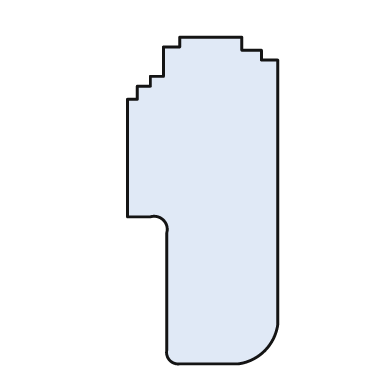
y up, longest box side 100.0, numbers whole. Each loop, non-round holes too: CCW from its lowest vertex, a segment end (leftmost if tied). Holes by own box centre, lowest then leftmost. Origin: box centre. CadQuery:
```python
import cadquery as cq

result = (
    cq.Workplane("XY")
    .moveTo(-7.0, -50.0)
    .lineTo(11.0, -50.0)
    .threePointArc((19.0, -46.0), (23.0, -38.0))
    .lineTo(23.0, 43.0)
    .lineTo(18.0, 43.0)
    .lineTo(18.0, 46.0)
    .lineTo(12.0, 46.0)
    .lineTo(12.0, 50.0)
    .lineTo(-7.0, 50.0)
    .lineTo(-7.0, 47.0)
    .lineTo(-12.0, 47.0)
    .lineTo(-12.0, 38.0)
    .lineTo(-16.0, 38.0)
    .lineTo(-16.0, 35.0)
    .lineTo(-20.0, 35.0)
    .lineTo(-20.0, 31.0)
    .lineTo(-23.0, 31.0)
    .lineTo(-23.0, -5.0)
    .lineTo(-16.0, -5.0)
    .threePointArc((-12.0, -6.0), (-11.0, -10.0))
    .lineTo(-11.0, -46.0)
    .threePointArc((-10.0, -49.0), (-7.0, -50.0))
    .close()
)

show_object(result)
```